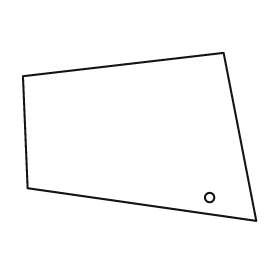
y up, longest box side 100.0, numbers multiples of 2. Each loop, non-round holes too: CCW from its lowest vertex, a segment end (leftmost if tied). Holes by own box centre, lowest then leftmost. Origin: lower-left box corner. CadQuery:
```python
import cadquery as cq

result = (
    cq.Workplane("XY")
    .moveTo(100.0, 0.0)
    .lineTo(86.0, 72.0)
    .lineTo(0.0, 62.0)
    .lineTo(2.0, 14.0)
    .close()
    .moveTo(80.0, 10.0)
    .circle(2.0)
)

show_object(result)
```